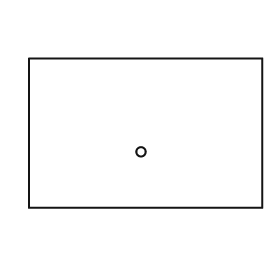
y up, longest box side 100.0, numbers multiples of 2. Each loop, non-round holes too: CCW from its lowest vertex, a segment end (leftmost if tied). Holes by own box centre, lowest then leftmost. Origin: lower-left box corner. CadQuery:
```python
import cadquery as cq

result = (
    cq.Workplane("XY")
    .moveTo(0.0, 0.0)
    .lineTo(100.0, 0.0)
    .lineTo(100.0, 64.0)
    .lineTo(0.0, 64.0)
    .close()
    .moveTo(48.0, 24.0)
    .circle(2.0)
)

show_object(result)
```